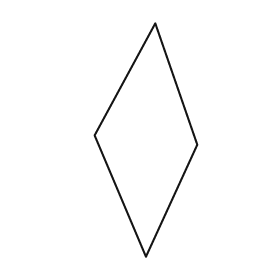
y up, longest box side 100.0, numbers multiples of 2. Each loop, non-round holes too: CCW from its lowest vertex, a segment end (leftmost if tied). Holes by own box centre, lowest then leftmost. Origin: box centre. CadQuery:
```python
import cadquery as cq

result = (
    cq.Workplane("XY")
    .moveTo(0.0, -50.0)
    .lineTo(22.0, -2.0)
    .lineTo(4.0, 50.0)
    .lineTo(-22.0, 2.0)
    .close()
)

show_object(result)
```